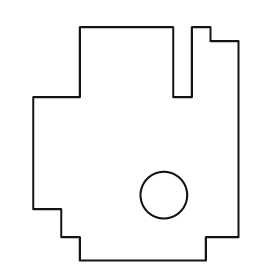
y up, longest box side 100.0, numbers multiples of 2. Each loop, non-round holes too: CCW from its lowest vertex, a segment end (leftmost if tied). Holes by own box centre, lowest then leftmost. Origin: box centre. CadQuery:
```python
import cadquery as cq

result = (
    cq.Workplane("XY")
    .moveTo(-24.0, -50.0)
    .lineTo(30.0, -50.0)
    .lineTo(30.0, -40.0)
    .lineTo(44.0, -40.0)
    .lineTo(44.0, 44.0)
    .lineTo(32.0, 44.0)
    .lineTo(32.0, 50.0)
    .lineTo(24.0, 50.0)
    .lineTo(24.0, 20.0)
    .lineTo(16.0, 20.0)
    .lineTo(16.0, 50.0)
    .lineTo(-24.0, 50.0)
    .lineTo(-24.0, 20.0)
    .lineTo(-44.0, 20.0)
    .lineTo(-44.0, -28.0)
    .lineTo(-32.0, -28.0)
    .lineTo(-32.0, -40.0)
    .lineTo(-24.0, -40.0)
    .close()
    .moveTo(12.0, -22.0)
    .circle(10.0)
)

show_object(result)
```